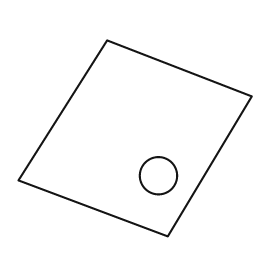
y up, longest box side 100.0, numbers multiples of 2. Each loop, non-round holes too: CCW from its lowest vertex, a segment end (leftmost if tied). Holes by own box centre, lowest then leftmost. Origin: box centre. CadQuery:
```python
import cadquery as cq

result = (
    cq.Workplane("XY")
    .moveTo(14.0, -42.0)
    .lineTo(50.0, 18.0)
    .lineTo(-12.0, 42.0)
    .lineTo(-50.0, -18.0)
    .close()
    .moveTo(10.0, -16.0)
    .circle(8.0)
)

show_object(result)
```